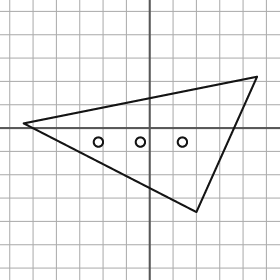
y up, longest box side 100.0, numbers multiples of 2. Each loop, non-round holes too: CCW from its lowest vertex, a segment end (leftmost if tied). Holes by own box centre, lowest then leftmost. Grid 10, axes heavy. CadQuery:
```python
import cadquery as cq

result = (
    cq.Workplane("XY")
    .moveTo(20.0, -36.0)
    .lineTo(46.0, 22.0)
    .lineTo(-54.0, 2.0)
    .close()
    .moveTo(-22.0, -6.0)
    .circle(2.0)
    .moveTo(-4.0, -6.0)
    .circle(2.0)
    .moveTo(14.0, -6.0)
    .circle(2.0)
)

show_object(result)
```